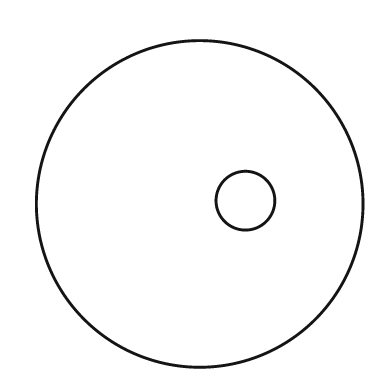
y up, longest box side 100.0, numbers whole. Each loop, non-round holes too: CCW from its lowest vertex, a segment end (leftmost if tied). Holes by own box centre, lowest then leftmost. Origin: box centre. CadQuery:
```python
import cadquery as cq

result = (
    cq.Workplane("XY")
    .moveTo(0.0, 0.0)
    .circle(50.0)
    .moveTo(14.0, 1.0)
    .circle(9.0)
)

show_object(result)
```